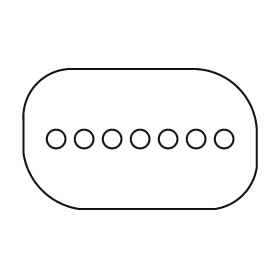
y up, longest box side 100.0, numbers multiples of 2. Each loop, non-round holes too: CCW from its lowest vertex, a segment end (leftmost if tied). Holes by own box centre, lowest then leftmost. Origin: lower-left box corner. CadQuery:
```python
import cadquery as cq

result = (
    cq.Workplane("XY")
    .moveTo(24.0, 0.0)
    .lineTo(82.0, 0.0)
    .threePointArc((94.0, 6.0), (100.0, 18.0))
    .lineTo(100.0, 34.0)
    .threePointArc((92.0, 52.0), (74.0, 60.0))
    .lineTo(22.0, 60.0)
    .threePointArc((6.0, 54.0), (0.0, 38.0))
    .lineTo(0.0, 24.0)
    .threePointArc((8.0, 8.0), (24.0, 0.0))
    .close()
    .moveTo(14.0, 30.0)
    .circle(4.0)
    .moveTo(26.0, 30.0)
    .circle(4.0)
    .moveTo(38.0, 30.0)
    .circle(4.0)
    .moveTo(50.0, 30.0)
    .circle(4.0)
    .moveTo(62.0, 30.0)
    .circle(4.0)
    .moveTo(74.0, 30.0)
    .circle(4.0)
    .moveTo(86.0, 30.0)
    .circle(4.0)
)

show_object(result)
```